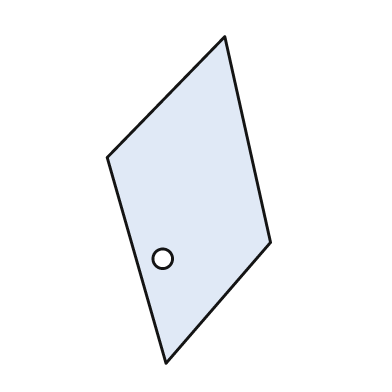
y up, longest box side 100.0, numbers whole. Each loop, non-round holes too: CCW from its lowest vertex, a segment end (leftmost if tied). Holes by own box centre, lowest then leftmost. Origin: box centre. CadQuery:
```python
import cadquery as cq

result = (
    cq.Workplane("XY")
    .moveTo(-7.0, -50.0)
    .lineTo(25.0, -13.0)
    .lineTo(11.0, 50.0)
    .lineTo(-25.0, 13.0)
    .close()
    .moveTo(-8.0, -18.0)
    .circle(3.0)
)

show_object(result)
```